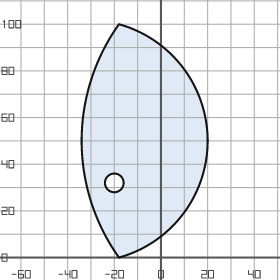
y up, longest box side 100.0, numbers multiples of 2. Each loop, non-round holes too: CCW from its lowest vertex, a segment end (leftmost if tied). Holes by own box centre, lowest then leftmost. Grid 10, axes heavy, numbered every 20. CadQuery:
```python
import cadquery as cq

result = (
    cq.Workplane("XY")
    .moveTo(-18.0, 0.0)
    .threePointArc((20.0, 50.0), (-18.0, 100.0))
    .threePointArc((-34.0, 50.0), (-18.0, 0.0))
    .close()
    .moveTo(-20.0, 32.0)
    .circle(4.0)
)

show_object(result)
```